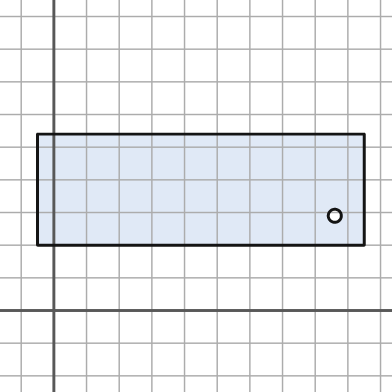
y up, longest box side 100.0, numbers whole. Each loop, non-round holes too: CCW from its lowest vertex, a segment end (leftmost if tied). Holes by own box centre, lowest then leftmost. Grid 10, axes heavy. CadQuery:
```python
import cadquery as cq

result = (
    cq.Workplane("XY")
    .moveTo(-5.0, 20.0)
    .lineTo(95.0, 20.0)
    .lineTo(95.0, 54.0)
    .lineTo(-5.0, 54.0)
    .close()
    .moveTo(86.0, 29.0)
    .circle(2.0)
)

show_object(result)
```